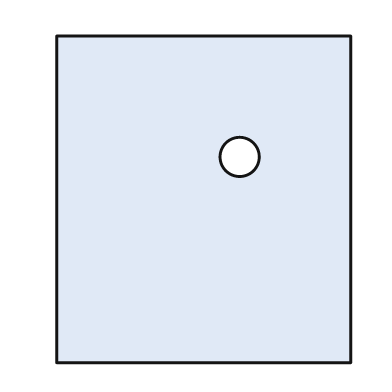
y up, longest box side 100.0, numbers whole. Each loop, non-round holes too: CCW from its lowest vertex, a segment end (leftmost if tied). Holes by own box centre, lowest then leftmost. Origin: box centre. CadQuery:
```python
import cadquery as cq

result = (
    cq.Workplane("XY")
    .moveTo(-45.0, -50.0)
    .lineTo(45.0, -50.0)
    .lineTo(45.0, 50.0)
    .lineTo(-45.0, 50.0)
    .close()
    .moveTo(11.0, 13.0)
    .circle(6.0)
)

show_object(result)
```